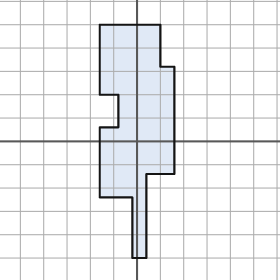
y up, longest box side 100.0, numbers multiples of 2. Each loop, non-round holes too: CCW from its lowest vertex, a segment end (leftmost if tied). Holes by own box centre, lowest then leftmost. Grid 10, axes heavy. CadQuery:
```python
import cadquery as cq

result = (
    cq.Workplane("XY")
    .moveTo(-2.0, -50.0)
    .lineTo(4.0, -50.0)
    .lineTo(4.0, -14.0)
    .lineTo(16.0, -14.0)
    .lineTo(16.0, 32.0)
    .lineTo(10.0, 32.0)
    .lineTo(10.0, 50.0)
    .lineTo(-16.0, 50.0)
    .lineTo(-16.0, 20.0)
    .lineTo(-8.0, 20.0)
    .lineTo(-8.0, 6.0)
    .lineTo(-16.0, 6.0)
    .lineTo(-16.0, -24.0)
    .lineTo(-2.0, -24.0)
    .close()
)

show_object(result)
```